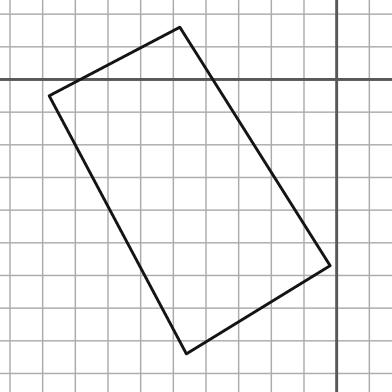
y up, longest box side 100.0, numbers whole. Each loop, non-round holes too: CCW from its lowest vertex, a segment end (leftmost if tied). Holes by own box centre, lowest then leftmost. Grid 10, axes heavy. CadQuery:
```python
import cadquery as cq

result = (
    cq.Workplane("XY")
    .moveTo(-46.0, -84.0)
    .lineTo(-2.0, -57.0)
    .lineTo(-48.0, 16.0)
    .lineTo(-88.0, -5.0)
    .close()
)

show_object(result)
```